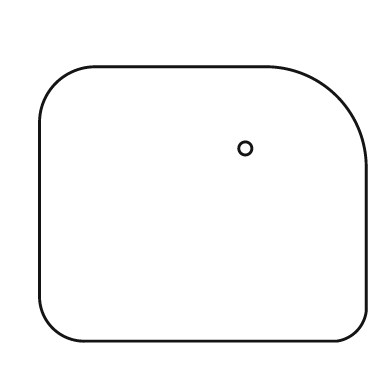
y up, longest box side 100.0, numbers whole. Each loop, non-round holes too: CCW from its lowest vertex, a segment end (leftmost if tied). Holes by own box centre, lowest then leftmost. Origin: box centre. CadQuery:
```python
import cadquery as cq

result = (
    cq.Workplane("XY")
    .moveTo(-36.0, -42.0)
    .lineTo(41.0, -42.0)
    .threePointArc((47.0, -39.0), (50.0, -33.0))
    .lineTo(50.0, 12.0)
    .threePointArc((41.0, 33.0), (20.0, 42.0))
    .lineTo(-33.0, 42.0)
    .threePointArc((-45.0, 37.0), (-50.0, 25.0))
    .lineTo(-50.0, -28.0)
    .threePointArc((-46.0, -38.0), (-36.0, -42.0))
    .close()
    .moveTo(13.0, 17.0)
    .circle(2.0)
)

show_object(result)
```